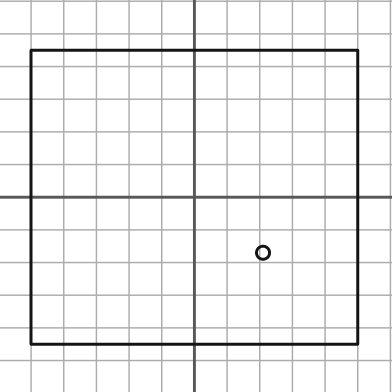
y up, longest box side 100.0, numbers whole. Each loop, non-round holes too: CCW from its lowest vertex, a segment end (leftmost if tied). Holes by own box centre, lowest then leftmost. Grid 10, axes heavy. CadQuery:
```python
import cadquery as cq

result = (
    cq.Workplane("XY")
    .moveTo(-50.0, -45.0)
    .lineTo(50.0, -45.0)
    .lineTo(50.0, 45.0)
    .lineTo(-50.0, 45.0)
    .close()
    .moveTo(21.0, -17.0)
    .circle(2.0)
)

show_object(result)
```